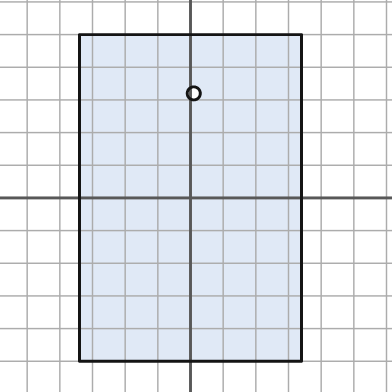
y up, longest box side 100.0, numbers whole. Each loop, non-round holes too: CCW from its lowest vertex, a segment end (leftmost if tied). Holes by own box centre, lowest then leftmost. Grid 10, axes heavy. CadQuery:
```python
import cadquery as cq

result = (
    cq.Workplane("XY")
    .moveTo(-34.0, -50.0)
    .lineTo(34.0, -50.0)
    .lineTo(34.0, 50.0)
    .lineTo(-34.0, 50.0)
    .close()
    .moveTo(1.0, 32.0)
    .circle(2.0)
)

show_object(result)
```